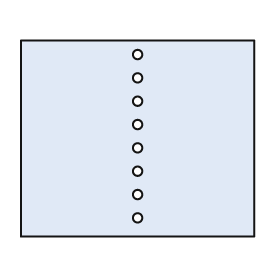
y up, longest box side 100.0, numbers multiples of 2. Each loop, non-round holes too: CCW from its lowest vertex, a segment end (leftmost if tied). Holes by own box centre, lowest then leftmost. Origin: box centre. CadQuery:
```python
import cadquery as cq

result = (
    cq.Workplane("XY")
    .moveTo(-50.0, -42.0)
    .lineTo(50.0, -42.0)
    .lineTo(50.0, 42.0)
    .lineTo(-50.0, 42.0)
    .close()
    .moveTo(0.0, -34.0)
    .circle(2.0)
    .moveTo(0.0, -24.0)
    .circle(2.0)
    .moveTo(0.0, -14.0)
    .circle(2.0)
    .moveTo(0.0, -4.0)
    .circle(2.0)
    .moveTo(0.0, 6.0)
    .circle(2.0)
    .moveTo(0.0, 16.0)
    .circle(2.0)
    .moveTo(0.0, 26.0)
    .circle(2.0)
    .moveTo(0.0, 36.0)
    .circle(2.0)
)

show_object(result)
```